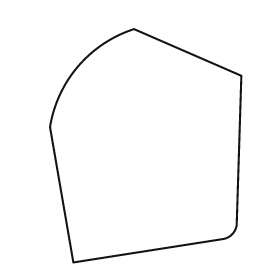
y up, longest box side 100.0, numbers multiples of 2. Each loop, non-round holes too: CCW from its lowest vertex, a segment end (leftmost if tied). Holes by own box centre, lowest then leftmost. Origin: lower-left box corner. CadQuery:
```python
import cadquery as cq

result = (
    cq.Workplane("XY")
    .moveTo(10.0, 0.0)
    .lineTo(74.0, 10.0)
    .threePointArc((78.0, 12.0), (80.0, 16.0))
    .lineTo(82.0, 80.0)
    .lineTo(36.0, 100.0)
    .threePointArc((12.0, 84.0), (0.0, 58.0))
    .close()
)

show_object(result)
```